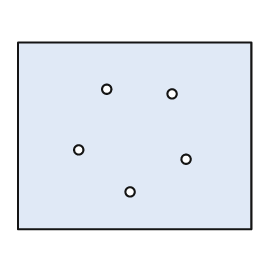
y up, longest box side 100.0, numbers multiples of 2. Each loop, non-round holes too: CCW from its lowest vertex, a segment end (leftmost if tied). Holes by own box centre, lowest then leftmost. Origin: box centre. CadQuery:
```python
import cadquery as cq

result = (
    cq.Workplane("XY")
    .moveTo(-50.0, -40.0)
    .lineTo(50.0, -40.0)
    .lineTo(50.0, 40.0)
    .lineTo(-50.0, 40.0)
    .close()
    .moveTo(-2.0, -24.0)
    .circle(2.0)
    .moveTo(22.0, -10.0)
    .circle(2.0)
    .moveTo(-24.0, -6.0)
    .circle(2.0)
    .moveTo(16.0, 18.0)
    .circle(2.0)
    .moveTo(-12.0, 20.0)
    .circle(2.0)
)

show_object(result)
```